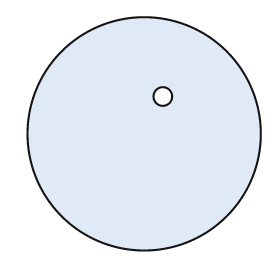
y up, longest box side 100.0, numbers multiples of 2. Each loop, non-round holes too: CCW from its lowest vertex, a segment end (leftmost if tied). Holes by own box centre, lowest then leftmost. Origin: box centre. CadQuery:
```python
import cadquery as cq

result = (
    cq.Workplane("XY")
    .moveTo(0.0, 0.0)
    .circle(50.0)
    .moveTo(8.0, 16.0)
    .circle(4.0)
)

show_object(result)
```